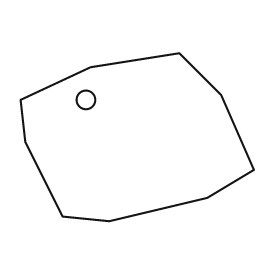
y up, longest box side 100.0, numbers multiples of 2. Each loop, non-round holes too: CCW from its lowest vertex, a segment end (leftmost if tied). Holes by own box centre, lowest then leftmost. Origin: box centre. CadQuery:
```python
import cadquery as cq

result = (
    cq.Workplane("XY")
    .moveTo(-12.0, -36.0)
    .lineTo(30.0, -26.0)
    .lineTo(50.0, -14.0)
    .lineTo(36.0, 18.0)
    .lineTo(18.0, 36.0)
    .lineTo(-20.0, 30.0)
    .lineTo(-50.0, 16.0)
    .lineTo(-48.0, -2.0)
    .lineTo(-32.0, -34.0)
    .close()
    .moveTo(-22.0, 16.0)
    .circle(4.0)
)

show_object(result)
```